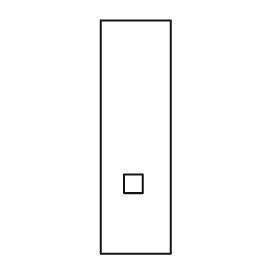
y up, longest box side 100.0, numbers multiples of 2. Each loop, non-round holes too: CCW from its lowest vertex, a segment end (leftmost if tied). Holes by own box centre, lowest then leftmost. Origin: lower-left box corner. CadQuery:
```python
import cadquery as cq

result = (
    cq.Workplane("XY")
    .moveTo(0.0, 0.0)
    .lineTo(30.0, 0.0)
    .lineTo(30.0, 100.0)
    .lineTo(0.0, 100.0)
    .close()
    .moveTo(10.0, 26.0)
    .lineTo(18.0, 26.0)
    .lineTo(18.0, 34.0)
    .lineTo(10.0, 34.0)
    .close()
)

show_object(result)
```